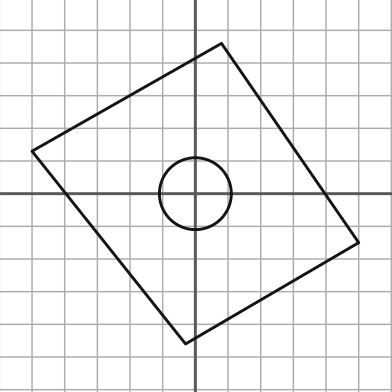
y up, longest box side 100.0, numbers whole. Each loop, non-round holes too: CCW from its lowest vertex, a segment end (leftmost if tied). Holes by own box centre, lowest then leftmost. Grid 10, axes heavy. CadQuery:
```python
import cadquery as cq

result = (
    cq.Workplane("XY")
    .moveTo(-3.0, -46.0)
    .lineTo(50.0, -15.0)
    .lineTo(8.0, 46.0)
    .lineTo(-50.0, 13.0)
    .close()
    .moveTo(0.0, 0.0)
    .circle(11.0)
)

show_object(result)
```